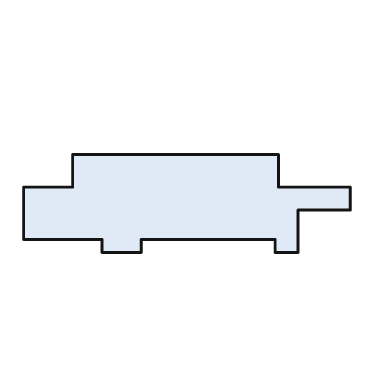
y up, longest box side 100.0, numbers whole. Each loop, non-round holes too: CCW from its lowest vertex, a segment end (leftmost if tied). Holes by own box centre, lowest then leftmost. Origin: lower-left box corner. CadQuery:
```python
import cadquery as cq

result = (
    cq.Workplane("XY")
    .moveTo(24.0, 0.0)
    .lineTo(36.0, 0.0)
    .lineTo(36.0, 4.0)
    .lineTo(77.0, 4.0)
    .lineTo(77.0, 0.0)
    .lineTo(84.0, 0.0)
    .lineTo(84.0, 13.0)
    .lineTo(100.0, 13.0)
    .lineTo(100.0, 20.0)
    .lineTo(78.0, 20.0)
    .lineTo(78.0, 30.0)
    .lineTo(15.0, 30.0)
    .lineTo(15.0, 20.0)
    .lineTo(0.0, 20.0)
    .lineTo(0.0, 4.0)
    .lineTo(24.0, 4.0)
    .close()
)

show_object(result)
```